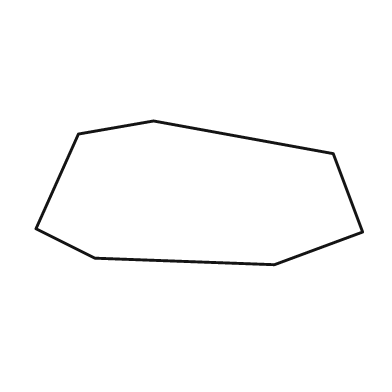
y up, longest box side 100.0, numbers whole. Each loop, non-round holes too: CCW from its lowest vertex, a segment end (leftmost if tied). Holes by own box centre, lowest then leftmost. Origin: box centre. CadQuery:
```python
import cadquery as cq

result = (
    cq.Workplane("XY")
    .moveTo(23.0, -22.0)
    .lineTo(50.0, -12.0)
    .lineTo(41.0, 12.0)
    .lineTo(-14.0, 22.0)
    .lineTo(-37.0, 18.0)
    .lineTo(-50.0, -11.0)
    .lineTo(-32.0, -20.0)
    .close()
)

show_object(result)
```